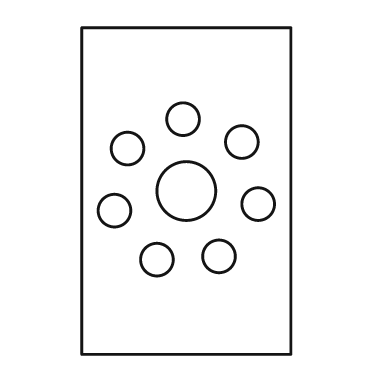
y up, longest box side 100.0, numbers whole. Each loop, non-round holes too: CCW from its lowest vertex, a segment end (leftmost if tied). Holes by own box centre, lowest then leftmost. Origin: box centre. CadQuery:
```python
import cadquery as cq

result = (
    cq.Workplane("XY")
    .moveTo(-32.0, -50.0)
    .lineTo(32.0, -50.0)
    .lineTo(32.0, 50.0)
    .lineTo(-32.0, 50.0)
    .close()
    .moveTo(-9.0, -21.0)
    .circle(5.0)
    .moveTo(10.0, -20.0)
    .circle(5.0)
    .moveTo(-22.0, -6.0)
    .circle(5.0)
    .moveTo(22.0, -4.0)
    .circle(5.0)
    .moveTo(0.0, 0.0)
    .circle(9.0)
    .moveTo(-18.0, 13.0)
    .circle(5.0)
    .moveTo(17.0, 15.0)
    .circle(5.0)
    .moveTo(-1.0, 22.0)
    .circle(5.0)
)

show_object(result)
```